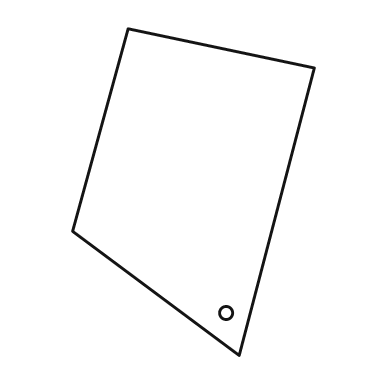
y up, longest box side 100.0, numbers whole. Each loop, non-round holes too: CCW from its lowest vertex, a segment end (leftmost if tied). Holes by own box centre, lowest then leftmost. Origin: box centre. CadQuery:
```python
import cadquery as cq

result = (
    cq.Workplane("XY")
    .moveTo(14.0, -50.0)
    .lineTo(37.0, 38.0)
    .lineTo(-20.0, 50.0)
    .lineTo(-37.0, -12.0)
    .close()
    .moveTo(10.0, -37.0)
    .circle(2.0)
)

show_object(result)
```